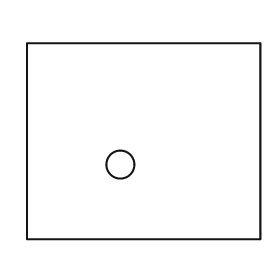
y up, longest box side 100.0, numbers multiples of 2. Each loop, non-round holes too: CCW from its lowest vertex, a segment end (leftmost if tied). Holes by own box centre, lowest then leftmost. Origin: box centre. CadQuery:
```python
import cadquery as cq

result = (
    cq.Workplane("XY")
    .moveTo(-50.0, -42.0)
    .lineTo(50.0, -42.0)
    .lineTo(50.0, 42.0)
    .lineTo(-50.0, 42.0)
    .close()
    .moveTo(-10.0, -10.0)
    .circle(6.0)
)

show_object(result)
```